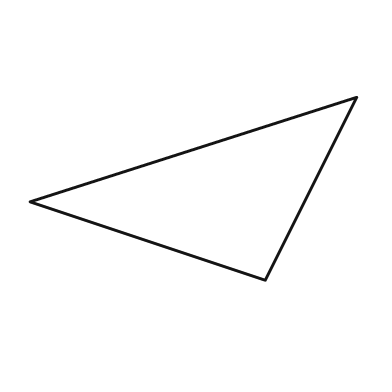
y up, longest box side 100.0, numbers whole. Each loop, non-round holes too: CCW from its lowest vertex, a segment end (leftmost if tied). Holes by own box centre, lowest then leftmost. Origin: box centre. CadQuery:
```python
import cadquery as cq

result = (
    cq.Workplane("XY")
    .moveTo(22.0, -28.0)
    .lineTo(50.0, 28.0)
    .lineTo(-50.0, -4.0)
    .close()
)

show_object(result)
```